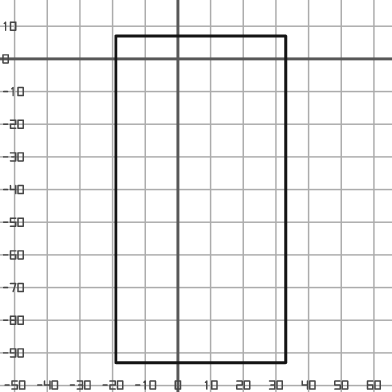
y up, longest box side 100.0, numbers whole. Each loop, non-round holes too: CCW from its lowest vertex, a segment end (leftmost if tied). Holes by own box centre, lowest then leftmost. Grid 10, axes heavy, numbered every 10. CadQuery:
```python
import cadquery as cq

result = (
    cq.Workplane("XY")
    .moveTo(-19.0, -93.0)
    .lineTo(33.0, -93.0)
    .lineTo(33.0, 7.0)
    .lineTo(-19.0, 7.0)
    .close()
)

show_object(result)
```